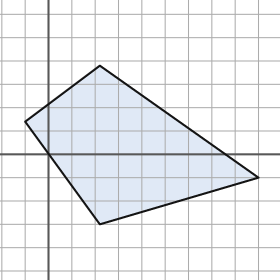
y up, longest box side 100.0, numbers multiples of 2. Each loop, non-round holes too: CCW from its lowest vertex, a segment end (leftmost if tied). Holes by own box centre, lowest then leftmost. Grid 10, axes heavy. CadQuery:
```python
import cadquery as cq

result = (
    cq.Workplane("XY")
    .moveTo(22.0, -30.0)
    .lineTo(90.0, -10.0)
    .lineTo(22.0, 38.0)
    .lineTo(-10.0, 14.0)
    .close()
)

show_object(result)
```